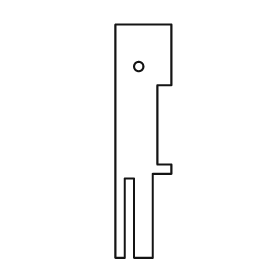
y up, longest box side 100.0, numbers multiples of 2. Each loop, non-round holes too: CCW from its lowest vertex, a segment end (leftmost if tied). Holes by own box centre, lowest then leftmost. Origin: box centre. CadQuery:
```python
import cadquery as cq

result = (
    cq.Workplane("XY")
    .moveTo(-12.0, -50.0)
    .lineTo(-8.0, -50.0)
    .lineTo(-8.0, -16.0)
    .lineTo(-4.0, -16.0)
    .lineTo(-4.0, -50.0)
    .lineTo(4.0, -50.0)
    .lineTo(4.0, -14.0)
    .lineTo(12.0, -14.0)
    .lineTo(12.0, -10.0)
    .lineTo(6.0, -10.0)
    .lineTo(6.0, 24.0)
    .lineTo(12.0, 24.0)
    .lineTo(12.0, 50.0)
    .lineTo(-12.0, 50.0)
    .close()
    .moveTo(-2.0, 32.0)
    .circle(2.0)
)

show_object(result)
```